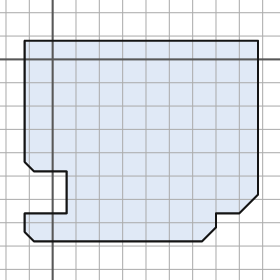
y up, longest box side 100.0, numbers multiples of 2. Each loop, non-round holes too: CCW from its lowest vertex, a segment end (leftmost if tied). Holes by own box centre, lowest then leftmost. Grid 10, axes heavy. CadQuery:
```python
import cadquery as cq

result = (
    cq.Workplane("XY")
    .moveTo(-8.0, -78.0)
    .lineTo(64.0, -78.0)
    .lineTo(70.0, -72.0)
    .lineTo(70.0, -66.0)
    .lineTo(80.0, -66.0)
    .lineTo(88.0, -58.0)
    .lineTo(88.0, 8.0)
    .lineTo(-12.0, 8.0)
    .lineTo(-12.0, -44.0)
    .lineTo(-8.0, -48.0)
    .lineTo(6.0, -48.0)
    .lineTo(6.0, -66.0)
    .lineTo(-12.0, -66.0)
    .lineTo(-12.0, -74.0)
    .close()
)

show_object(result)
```